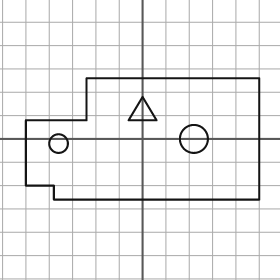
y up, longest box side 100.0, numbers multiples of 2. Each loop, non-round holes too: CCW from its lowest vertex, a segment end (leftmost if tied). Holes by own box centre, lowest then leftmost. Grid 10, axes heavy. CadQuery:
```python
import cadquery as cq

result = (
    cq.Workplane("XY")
    .moveTo(-38.0, -26.0)
    .lineTo(50.0, -26.0)
    .lineTo(50.0, 26.0)
    .lineTo(-24.0, 26.0)
    .lineTo(-24.0, 8.0)
    .lineTo(-50.0, 8.0)
    .lineTo(-50.0, -20.0)
    .lineTo(-38.0, -20.0)
    .close()
    .moveTo(-36.0, -2.0)
    .circle(4.0)
    .moveTo(22.0, 0.0)
    .circle(6.0)
    .moveTo(-6.0, 8.0)
    .lineTo(6.0, 8.0)
    .lineTo(0.0, 18.0)
    .close()
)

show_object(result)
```